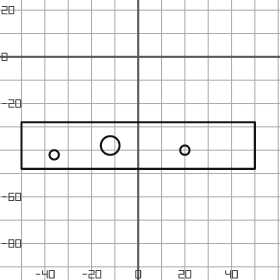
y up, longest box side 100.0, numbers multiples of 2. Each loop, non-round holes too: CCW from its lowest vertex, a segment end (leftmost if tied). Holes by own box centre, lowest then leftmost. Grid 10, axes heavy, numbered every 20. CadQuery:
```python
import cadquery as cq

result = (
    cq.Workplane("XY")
    .moveTo(-50.0, -48.0)
    .lineTo(50.0, -48.0)
    .lineTo(50.0, -28.0)
    .lineTo(-50.0, -28.0)
    .close()
    .moveTo(-36.0, -42.0)
    .circle(2.0)
    .moveTo(20.0, -40.0)
    .circle(2.0)
    .moveTo(-12.0, -38.0)
    .circle(4.0)
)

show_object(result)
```